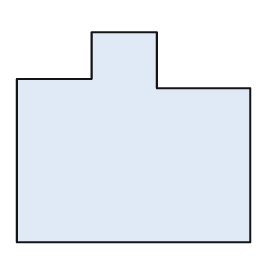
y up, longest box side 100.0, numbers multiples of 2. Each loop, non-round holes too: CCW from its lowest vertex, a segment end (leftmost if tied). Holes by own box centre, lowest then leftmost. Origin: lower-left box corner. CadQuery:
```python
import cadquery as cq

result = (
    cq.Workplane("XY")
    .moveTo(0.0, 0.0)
    .lineTo(100.0, 0.0)
    .lineTo(100.0, 66.0)
    .lineTo(60.0, 66.0)
    .lineTo(60.0, 90.0)
    .lineTo(32.0, 90.0)
    .lineTo(32.0, 70.0)
    .lineTo(0.0, 70.0)
    .close()
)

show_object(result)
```